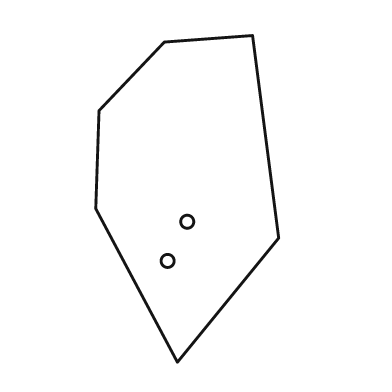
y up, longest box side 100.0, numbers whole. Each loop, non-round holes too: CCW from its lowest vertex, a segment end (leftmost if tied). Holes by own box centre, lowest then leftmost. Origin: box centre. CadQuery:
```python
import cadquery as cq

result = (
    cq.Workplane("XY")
    .moveTo(-3.0, -50.0)
    .lineTo(28.0, -12.0)
    .lineTo(20.0, 50.0)
    .lineTo(-7.0, 48.0)
    .lineTo(-27.0, 27.0)
    .lineTo(-28.0, -3.0)
    .close()
    .moveTo(-6.0, -19.0)
    .circle(2.0)
    .moveTo(0.0, -7.0)
    .circle(2.0)
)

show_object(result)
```